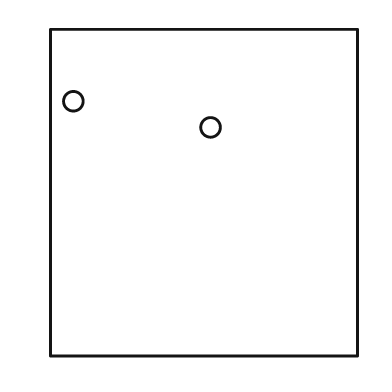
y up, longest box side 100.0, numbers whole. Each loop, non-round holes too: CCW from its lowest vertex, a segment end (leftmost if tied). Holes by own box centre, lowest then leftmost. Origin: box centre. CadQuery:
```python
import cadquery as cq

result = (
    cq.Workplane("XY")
    .moveTo(-47.0, -50.0)
    .lineTo(47.0, -50.0)
    .lineTo(47.0, 50.0)
    .lineTo(-47.0, 50.0)
    .close()
    .moveTo(2.0, 20.0)
    .circle(3.0)
    .moveTo(-40.0, 28.0)
    .circle(3.0)
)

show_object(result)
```